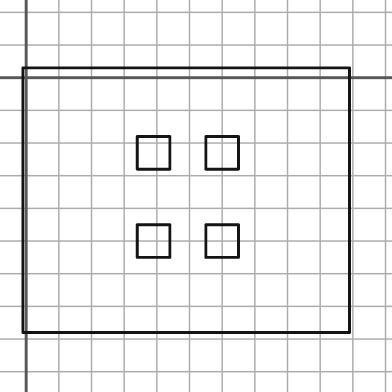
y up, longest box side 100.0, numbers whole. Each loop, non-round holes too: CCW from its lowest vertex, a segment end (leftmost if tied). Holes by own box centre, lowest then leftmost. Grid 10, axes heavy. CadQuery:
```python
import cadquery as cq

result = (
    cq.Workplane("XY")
    .moveTo(-1.0, -78.0)
    .lineTo(99.0, -78.0)
    .lineTo(99.0, 3.0)
    .lineTo(-1.0, 3.0)
    .close()
    .moveTo(34.0, -55.0)
    .lineTo(44.0, -55.0)
    .lineTo(44.0, -45.0)
    .lineTo(34.0, -45.0)
    .close()
    .moveTo(55.0, -55.0)
    .lineTo(65.0, -55.0)
    .lineTo(65.0, -45.0)
    .lineTo(55.0, -45.0)
    .close()
    .moveTo(34.0, -28.0)
    .lineTo(44.0, -28.0)
    .lineTo(44.0, -18.0)
    .lineTo(34.0, -18.0)
    .close()
    .moveTo(55.0, -28.0)
    .lineTo(65.0, -28.0)
    .lineTo(65.0, -18.0)
    .lineTo(55.0, -18.0)
    .close()
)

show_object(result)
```